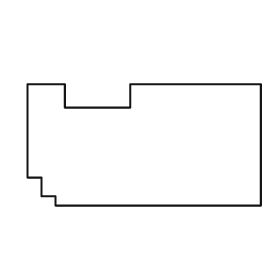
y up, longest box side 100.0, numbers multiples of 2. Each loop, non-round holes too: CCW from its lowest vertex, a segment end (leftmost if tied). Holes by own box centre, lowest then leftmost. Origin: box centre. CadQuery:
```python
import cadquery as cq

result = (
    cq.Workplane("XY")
    .moveTo(-38.0, -26.0)
    .lineTo(50.0, -26.0)
    .lineTo(50.0, 26.0)
    .lineTo(-6.0, 26.0)
    .lineTo(-6.0, 16.0)
    .lineTo(-34.0, 16.0)
    .lineTo(-34.0, 26.0)
    .lineTo(-50.0, 26.0)
    .lineTo(-50.0, -14.0)
    .lineTo(-44.0, -14.0)
    .lineTo(-44.0, -22.0)
    .lineTo(-38.0, -22.0)
    .close()
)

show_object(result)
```